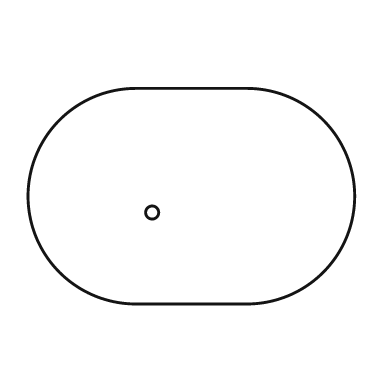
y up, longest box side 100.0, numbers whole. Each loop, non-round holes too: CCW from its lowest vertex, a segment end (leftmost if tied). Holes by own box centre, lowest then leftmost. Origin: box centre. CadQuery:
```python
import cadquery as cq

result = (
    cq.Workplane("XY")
    .moveTo(-17.0, -33.0)
    .lineTo(17.0, -33.0)
    .threePointArc((50.0, 0.0), (17.0, 33.0))
    .lineTo(-17.0, 33.0)
    .threePointArc((-50.0, 0.0), (-17.0, -33.0))
    .close()
    .moveTo(-12.0, -5.0)
    .circle(2.0)
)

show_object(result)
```